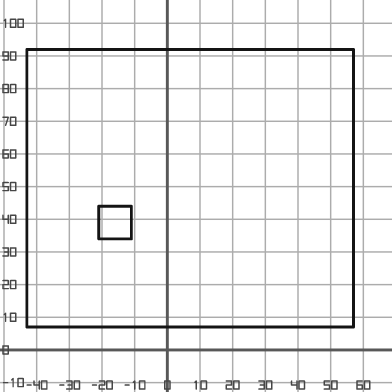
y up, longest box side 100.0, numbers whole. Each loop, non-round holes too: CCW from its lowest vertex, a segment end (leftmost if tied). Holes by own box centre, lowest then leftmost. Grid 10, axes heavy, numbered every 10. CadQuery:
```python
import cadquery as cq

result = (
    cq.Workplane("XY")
    .moveTo(-43.0, 7.0)
    .lineTo(57.0, 7.0)
    .lineTo(57.0, 92.0)
    .lineTo(-43.0, 92.0)
    .close()
    .moveTo(-21.0, 34.0)
    .lineTo(-11.0, 34.0)
    .lineTo(-11.0, 44.0)
    .lineTo(-21.0, 44.0)
    .close()
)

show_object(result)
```